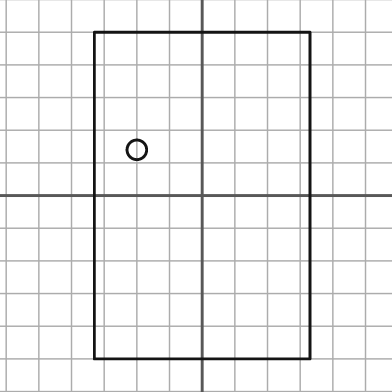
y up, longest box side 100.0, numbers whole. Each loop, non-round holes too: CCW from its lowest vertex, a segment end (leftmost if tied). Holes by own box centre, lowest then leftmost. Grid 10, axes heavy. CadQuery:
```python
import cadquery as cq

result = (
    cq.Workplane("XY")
    .moveTo(-33.0, -50.0)
    .lineTo(33.0, -50.0)
    .lineTo(33.0, 50.0)
    .lineTo(-33.0, 50.0)
    .close()
    .moveTo(-20.0, 14.0)
    .circle(3.0)
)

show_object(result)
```